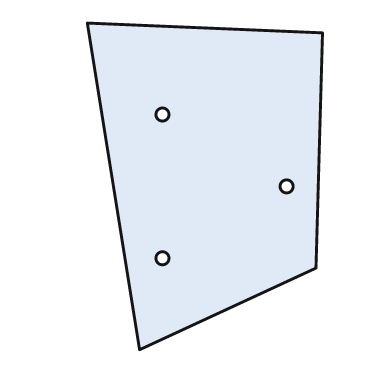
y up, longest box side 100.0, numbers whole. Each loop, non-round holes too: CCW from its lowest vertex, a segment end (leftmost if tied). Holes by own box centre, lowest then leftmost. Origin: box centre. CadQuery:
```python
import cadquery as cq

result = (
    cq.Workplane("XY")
    .moveTo(-20.0, -50.0)
    .lineTo(34.0, -25.0)
    .lineTo(36.0, 47.0)
    .lineTo(-36.0, 50.0)
    .close()
    .moveTo(-13.0, -22.0)
    .circle(2.0)
    .moveTo(25.0, 0.0)
    .circle(2.0)
    .moveTo(-13.0, 22.0)
    .circle(2.0)
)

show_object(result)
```